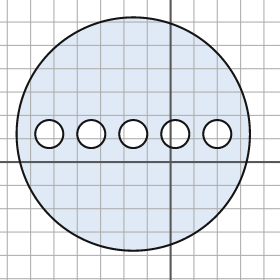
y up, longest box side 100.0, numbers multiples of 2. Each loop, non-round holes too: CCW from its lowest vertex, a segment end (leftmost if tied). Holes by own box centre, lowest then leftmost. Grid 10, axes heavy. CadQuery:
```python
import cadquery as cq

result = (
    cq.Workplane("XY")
    .moveTo(-16.0, 12.0)
    .circle(50.0)
    .moveTo(-52.0, 12.0)
    .circle(6.0)
    .moveTo(-34.0, 12.0)
    .circle(6.0)
    .moveTo(-16.0, 12.0)
    .circle(6.0)
    .moveTo(2.0, 12.0)
    .circle(6.0)
    .moveTo(20.0, 12.0)
    .circle(6.0)
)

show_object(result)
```